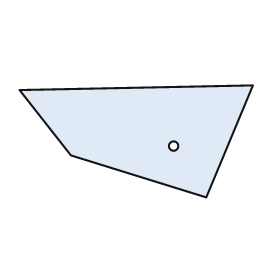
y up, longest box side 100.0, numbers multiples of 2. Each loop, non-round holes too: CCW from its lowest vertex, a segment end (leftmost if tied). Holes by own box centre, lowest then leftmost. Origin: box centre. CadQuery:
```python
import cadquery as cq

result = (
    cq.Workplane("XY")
    .moveTo(30.0, -24.0)
    .lineTo(50.0, 24.0)
    .lineTo(-50.0, 22.0)
    .lineTo(-28.0, -6.0)
    .close()
    .moveTo(16.0, -2.0)
    .circle(2.0)
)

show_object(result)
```